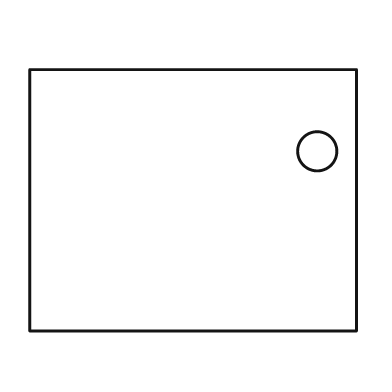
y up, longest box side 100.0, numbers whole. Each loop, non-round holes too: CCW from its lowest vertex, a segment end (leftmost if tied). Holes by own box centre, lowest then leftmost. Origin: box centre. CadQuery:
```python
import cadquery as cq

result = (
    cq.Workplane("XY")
    .moveTo(-50.0, -40.0)
    .lineTo(50.0, -40.0)
    .lineTo(50.0, 40.0)
    .lineTo(-50.0, 40.0)
    .close()
    .moveTo(38.0, 15.0)
    .circle(6.0)
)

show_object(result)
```